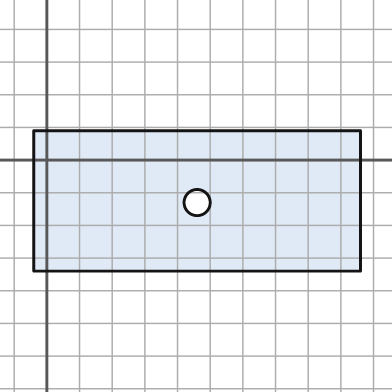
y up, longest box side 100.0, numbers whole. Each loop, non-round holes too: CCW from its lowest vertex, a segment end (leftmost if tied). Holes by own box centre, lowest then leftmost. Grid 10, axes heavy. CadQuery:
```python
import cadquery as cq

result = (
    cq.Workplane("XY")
    .moveTo(-4.0, -34.0)
    .lineTo(96.0, -34.0)
    .lineTo(96.0, 9.0)
    .lineTo(-4.0, 9.0)
    .close()
    .moveTo(46.0, -13.0)
    .circle(4.0)
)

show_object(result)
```